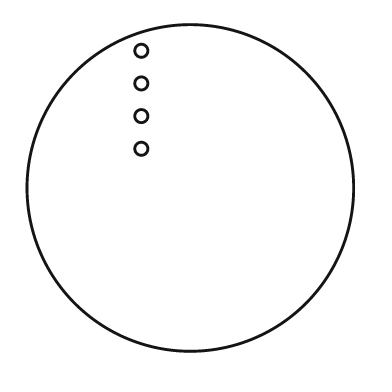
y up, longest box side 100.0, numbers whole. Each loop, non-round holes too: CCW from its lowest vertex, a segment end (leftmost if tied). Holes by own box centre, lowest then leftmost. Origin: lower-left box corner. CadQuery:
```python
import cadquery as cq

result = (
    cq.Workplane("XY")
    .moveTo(50.0, 50.0)
    .circle(50.0)
    .moveTo(35.0, 62.0)
    .circle(2.0)
    .moveTo(35.0, 72.0)
    .circle(2.0)
    .moveTo(35.0, 82.0)
    .circle(2.0)
    .moveTo(35.0, 92.0)
    .circle(2.0)
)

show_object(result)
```